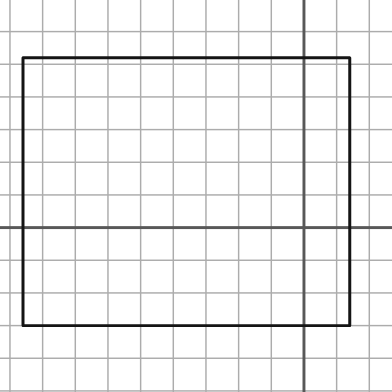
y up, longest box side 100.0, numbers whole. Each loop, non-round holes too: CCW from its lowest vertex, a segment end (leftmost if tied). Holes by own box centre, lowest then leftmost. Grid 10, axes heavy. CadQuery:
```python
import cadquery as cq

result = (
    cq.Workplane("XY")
    .moveTo(-86.0, -30.0)
    .lineTo(14.0, -30.0)
    .lineTo(14.0, 52.0)
    .lineTo(-86.0, 52.0)
    .close()
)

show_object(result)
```